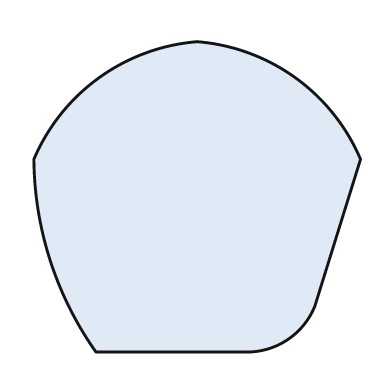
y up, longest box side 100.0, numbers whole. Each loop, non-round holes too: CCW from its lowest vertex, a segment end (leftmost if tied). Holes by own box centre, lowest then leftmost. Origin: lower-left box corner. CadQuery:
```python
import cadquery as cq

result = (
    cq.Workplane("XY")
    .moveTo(19.0, 0.0)
    .lineTo(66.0, 0.0)
    .threePointArc((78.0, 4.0), (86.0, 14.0))
    .lineTo(100.0, 59.0)
    .threePointArc((80.0, 84.0), (50.0, 95.0))
    .threePointArc((20.0, 84.0), (0.0, 59.0))
    .threePointArc((5.0, 28.0), (19.0, 0.0))
    .close()
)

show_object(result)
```